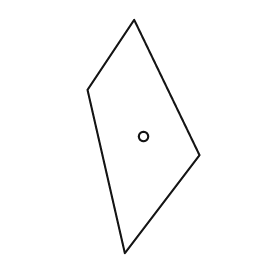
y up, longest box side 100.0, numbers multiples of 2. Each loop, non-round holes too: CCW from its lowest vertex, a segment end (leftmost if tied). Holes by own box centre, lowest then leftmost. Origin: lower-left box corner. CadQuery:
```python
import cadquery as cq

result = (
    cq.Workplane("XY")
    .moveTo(16.0, 0.0)
    .lineTo(48.0, 42.0)
    .lineTo(20.0, 100.0)
    .lineTo(0.0, 70.0)
    .close()
    .moveTo(24.0, 50.0)
    .circle(2.0)
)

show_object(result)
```